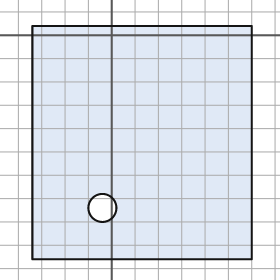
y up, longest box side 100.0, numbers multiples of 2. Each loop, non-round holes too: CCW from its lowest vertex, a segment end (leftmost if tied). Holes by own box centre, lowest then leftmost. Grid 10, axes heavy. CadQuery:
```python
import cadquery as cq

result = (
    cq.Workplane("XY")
    .moveTo(-34.0, -96.0)
    .lineTo(60.0, -96.0)
    .lineTo(60.0, 4.0)
    .lineTo(-34.0, 4.0)
    .close()
    .moveTo(-4.0, -74.0)
    .circle(6.0)
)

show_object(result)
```